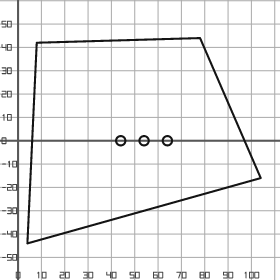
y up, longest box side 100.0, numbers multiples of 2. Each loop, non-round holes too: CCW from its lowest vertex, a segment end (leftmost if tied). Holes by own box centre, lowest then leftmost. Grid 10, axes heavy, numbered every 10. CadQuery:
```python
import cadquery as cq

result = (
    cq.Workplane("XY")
    .moveTo(4.0, -44.0)
    .lineTo(104.0, -16.0)
    .lineTo(78.0, 44.0)
    .lineTo(8.0, 42.0)
    .close()
    .moveTo(44.0, 0.0)
    .circle(2.0)
    .moveTo(54.0, 0.0)
    .circle(2.0)
    .moveTo(64.0, 0.0)
    .circle(2.0)
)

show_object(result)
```